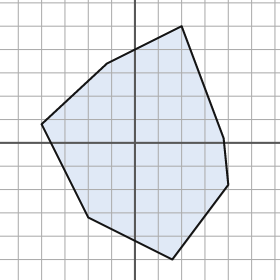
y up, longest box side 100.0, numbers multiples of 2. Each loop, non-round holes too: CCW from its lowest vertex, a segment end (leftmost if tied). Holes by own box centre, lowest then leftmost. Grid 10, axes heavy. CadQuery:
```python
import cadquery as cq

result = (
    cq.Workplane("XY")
    .moveTo(16.0, -50.0)
    .lineTo(40.0, -18.0)
    .lineTo(38.0, 2.0)
    .lineTo(20.0, 50.0)
    .lineTo(-12.0, 34.0)
    .lineTo(-40.0, 8.0)
    .lineTo(-20.0, -32.0)
    .close()
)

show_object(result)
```